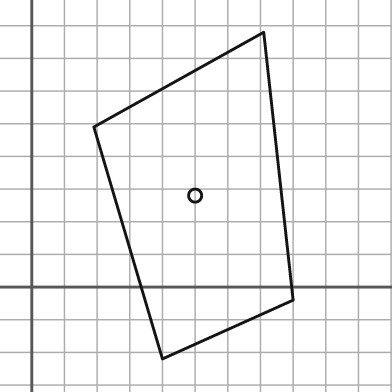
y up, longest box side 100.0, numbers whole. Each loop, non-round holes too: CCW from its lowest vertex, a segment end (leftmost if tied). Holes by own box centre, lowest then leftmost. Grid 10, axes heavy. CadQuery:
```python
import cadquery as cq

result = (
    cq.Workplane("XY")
    .moveTo(40.0, -22.0)
    .lineTo(80.0, -4.0)
    .lineTo(71.0, 78.0)
    .lineTo(19.0, 49.0)
    .close()
    .moveTo(50.0, 28.0)
    .circle(2.0)
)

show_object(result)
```